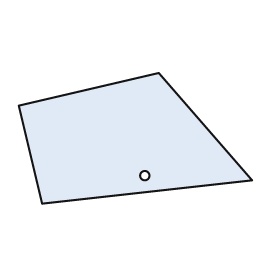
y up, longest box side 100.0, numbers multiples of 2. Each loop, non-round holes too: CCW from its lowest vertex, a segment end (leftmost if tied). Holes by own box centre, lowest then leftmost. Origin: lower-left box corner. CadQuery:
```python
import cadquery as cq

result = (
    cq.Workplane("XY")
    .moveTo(10.0, 0.0)
    .lineTo(100.0, 10.0)
    .lineTo(60.0, 56.0)
    .lineTo(0.0, 42.0)
    .close()
    .moveTo(54.0, 12.0)
    .circle(2.0)
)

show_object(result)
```